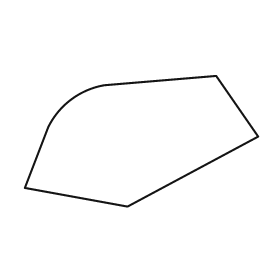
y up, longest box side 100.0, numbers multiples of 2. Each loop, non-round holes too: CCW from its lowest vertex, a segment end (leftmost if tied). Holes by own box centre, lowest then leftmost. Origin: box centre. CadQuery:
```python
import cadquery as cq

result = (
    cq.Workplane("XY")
    .moveTo(-6.0, -28.0)
    .lineTo(50.0, 2.0)
    .lineTo(32.0, 28.0)
    .lineTo(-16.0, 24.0)
    .threePointArc((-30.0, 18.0), (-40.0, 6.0))
    .lineTo(-50.0, -20.0)
    .close()
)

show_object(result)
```